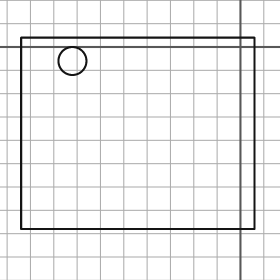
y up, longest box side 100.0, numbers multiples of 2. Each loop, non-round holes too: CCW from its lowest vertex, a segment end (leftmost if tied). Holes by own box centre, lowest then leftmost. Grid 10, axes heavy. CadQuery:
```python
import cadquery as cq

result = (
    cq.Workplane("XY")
    .moveTo(-94.0, -78.0)
    .lineTo(6.0, -78.0)
    .lineTo(6.0, 4.0)
    .lineTo(-94.0, 4.0)
    .close()
    .moveTo(-72.0, -6.0)
    .circle(6.0)
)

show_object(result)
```